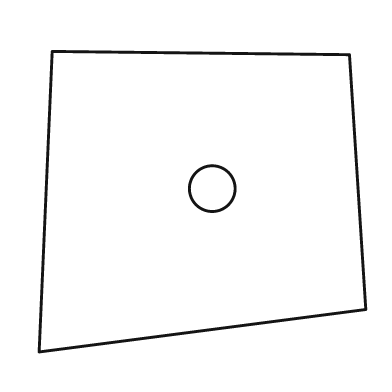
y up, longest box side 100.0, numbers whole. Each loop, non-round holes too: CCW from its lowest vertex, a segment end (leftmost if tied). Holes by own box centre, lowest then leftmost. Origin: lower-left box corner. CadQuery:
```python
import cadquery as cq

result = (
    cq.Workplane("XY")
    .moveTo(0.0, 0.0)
    .lineTo(100.0, 13.0)
    .lineTo(95.0, 91.0)
    .lineTo(4.0, 92.0)
    .close()
    .moveTo(53.0, 50.0)
    .circle(7.0)
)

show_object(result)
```